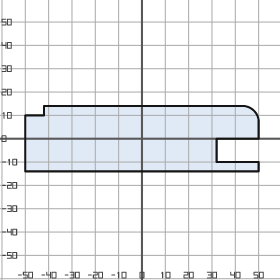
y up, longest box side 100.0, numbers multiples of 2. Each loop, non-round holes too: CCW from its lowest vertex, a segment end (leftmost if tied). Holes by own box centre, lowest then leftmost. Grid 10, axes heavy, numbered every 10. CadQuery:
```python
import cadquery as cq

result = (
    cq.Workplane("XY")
    .moveTo(-50.0, -14.0)
    .lineTo(50.0, -14.0)
    .lineTo(50.0, -10.0)
    .lineTo(32.0, -10.0)
    .lineTo(32.0, 0.0)
    .lineTo(50.0, 0.0)
    .lineTo(50.0, 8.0)
    .threePointArc((48.0, 12.0), (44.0, 14.0))
    .lineTo(-42.0, 14.0)
    .lineTo(-42.0, 10.0)
    .lineTo(-50.0, 10.0)
    .close()
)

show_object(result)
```